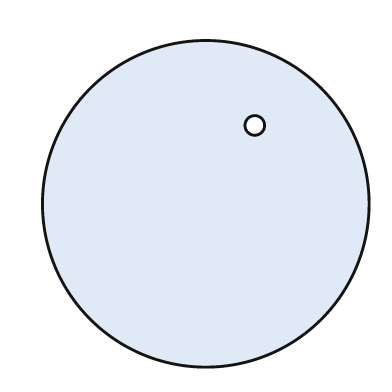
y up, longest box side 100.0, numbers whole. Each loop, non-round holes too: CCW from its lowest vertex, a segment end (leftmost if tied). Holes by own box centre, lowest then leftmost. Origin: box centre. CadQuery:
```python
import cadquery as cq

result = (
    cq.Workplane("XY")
    .moveTo(0.0, 0.0)
    .circle(50.0)
    .moveTo(15.0, 24.0)
    .circle(3.0)
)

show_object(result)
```